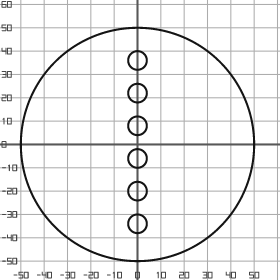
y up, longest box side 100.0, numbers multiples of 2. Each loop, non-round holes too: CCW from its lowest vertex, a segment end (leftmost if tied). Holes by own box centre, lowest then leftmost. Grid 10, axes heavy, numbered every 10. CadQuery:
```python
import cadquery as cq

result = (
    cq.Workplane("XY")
    .moveTo(0.0, 0.0)
    .circle(50.0)
    .moveTo(0.0, -34.0)
    .circle(4.0)
    .moveTo(0.0, -20.0)
    .circle(4.0)
    .moveTo(0.0, -6.0)
    .circle(4.0)
    .moveTo(0.0, 8.0)
    .circle(4.0)
    .moveTo(0.0, 22.0)
    .circle(4.0)
    .moveTo(0.0, 36.0)
    .circle(4.0)
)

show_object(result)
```